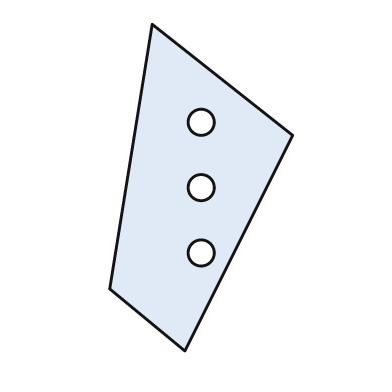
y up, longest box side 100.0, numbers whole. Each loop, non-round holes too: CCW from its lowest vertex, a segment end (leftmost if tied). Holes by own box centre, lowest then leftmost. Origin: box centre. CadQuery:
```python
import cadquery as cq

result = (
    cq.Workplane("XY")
    .moveTo(-5.0, -50.0)
    .lineTo(28.0, 16.0)
    .lineTo(-15.0, 50.0)
    .lineTo(-28.0, -31.0)
    .close()
    .moveTo(0.0, -20.0)
    .circle(4.0)
    .moveTo(0.0, 0.0)
    .circle(4.0)
    .moveTo(0.0, 20.0)
    .circle(4.0)
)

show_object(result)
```